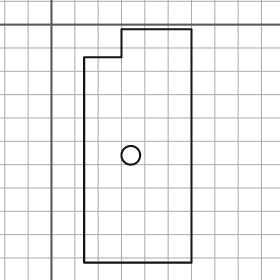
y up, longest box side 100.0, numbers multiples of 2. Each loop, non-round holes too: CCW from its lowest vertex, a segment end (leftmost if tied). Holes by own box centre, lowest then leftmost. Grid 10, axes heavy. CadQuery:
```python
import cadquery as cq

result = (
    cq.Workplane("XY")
    .moveTo(14.0, -102.0)
    .lineTo(60.0, -102.0)
    .lineTo(60.0, -2.0)
    .lineTo(30.0, -2.0)
    .lineTo(30.0, -14.0)
    .lineTo(14.0, -14.0)
    .close()
    .moveTo(34.0, -56.0)
    .circle(4.0)
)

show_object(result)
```